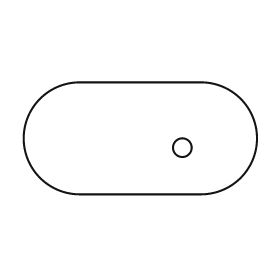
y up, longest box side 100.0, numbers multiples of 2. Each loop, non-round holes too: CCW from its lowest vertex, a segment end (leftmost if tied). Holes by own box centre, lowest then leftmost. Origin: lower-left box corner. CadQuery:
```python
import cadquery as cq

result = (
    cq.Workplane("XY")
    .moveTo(24.0, 0.0)
    .lineTo(76.0, 0.0)
    .threePointArc((100.0, 24.0), (76.0, 48.0))
    .lineTo(24.0, 48.0)
    .threePointArc((0.0, 24.0), (24.0, 0.0))
    .close()
    .moveTo(68.0, 20.0)
    .circle(4.0)
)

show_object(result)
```